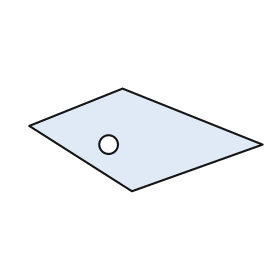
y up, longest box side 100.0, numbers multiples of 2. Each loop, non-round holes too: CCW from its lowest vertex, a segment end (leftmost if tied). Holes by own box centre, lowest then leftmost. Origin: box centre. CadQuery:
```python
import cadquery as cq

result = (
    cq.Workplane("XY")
    .moveTo(-6.0, -22.0)
    .lineTo(50.0, -2.0)
    .lineTo(-10.0, 22.0)
    .lineTo(-50.0, 6.0)
    .close()
    .moveTo(-16.0, -2.0)
    .circle(4.0)
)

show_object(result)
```